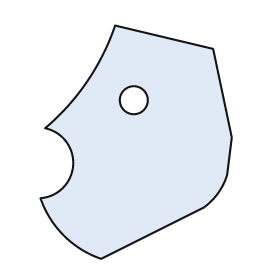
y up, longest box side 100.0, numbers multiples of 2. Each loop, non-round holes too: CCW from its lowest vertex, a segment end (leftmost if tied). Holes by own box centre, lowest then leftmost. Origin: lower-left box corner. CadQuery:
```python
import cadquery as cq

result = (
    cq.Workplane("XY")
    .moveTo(26.0, 0.0)
    .lineTo(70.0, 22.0)
    .threePointArc((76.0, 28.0), (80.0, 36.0))
    .lineTo(82.0, 52.0)
    .lineTo(74.0, 90.0)
    .lineTo(32.0, 100.0)
    .threePointArc((20.0, 76.0), (2.0, 56.0))
    .threePointArc((14.0, 40.0), (0.0, 26.0))
    .threePointArc((10.0, 10.0), (26.0, 0.0))
    .close()
    .moveTo(40.0, 68.0)
    .circle(6.0)
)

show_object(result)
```